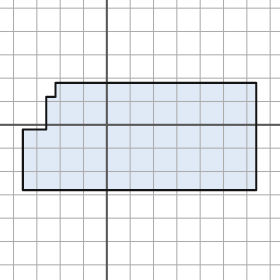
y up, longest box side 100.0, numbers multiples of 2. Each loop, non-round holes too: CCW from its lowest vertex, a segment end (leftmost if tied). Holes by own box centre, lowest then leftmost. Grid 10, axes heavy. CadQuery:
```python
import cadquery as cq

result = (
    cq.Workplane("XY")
    .moveTo(-36.0, -28.0)
    .lineTo(64.0, -28.0)
    .lineTo(64.0, 18.0)
    .lineTo(-22.0, 18.0)
    .lineTo(-22.0, 12.0)
    .lineTo(-26.0, 12.0)
    .lineTo(-26.0, -2.0)
    .lineTo(-36.0, -2.0)
    .close()
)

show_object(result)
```